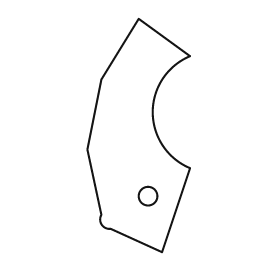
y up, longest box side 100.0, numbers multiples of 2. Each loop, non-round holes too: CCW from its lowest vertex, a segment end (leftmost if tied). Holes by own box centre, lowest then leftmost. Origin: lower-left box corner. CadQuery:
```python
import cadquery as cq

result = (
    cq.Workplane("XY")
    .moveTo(32.0, 0.0)
    .lineTo(44.0, 36.0)
    .threePointArc((28.0, 60.0), (44.0, 84.0))
    .lineTo(22.0, 100.0)
    .lineTo(6.0, 74.0)
    .lineTo(0.0, 44.0)
    .lineTo(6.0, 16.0)
    .threePointArc((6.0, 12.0), (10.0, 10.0))
    .close()
    .moveTo(26.0, 24.0)
    .circle(4.0)
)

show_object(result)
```